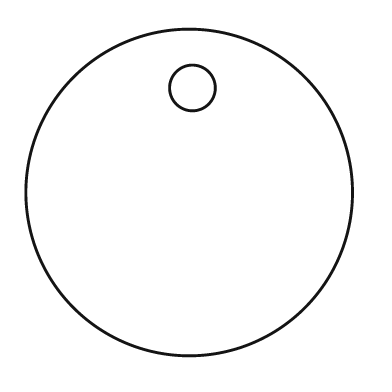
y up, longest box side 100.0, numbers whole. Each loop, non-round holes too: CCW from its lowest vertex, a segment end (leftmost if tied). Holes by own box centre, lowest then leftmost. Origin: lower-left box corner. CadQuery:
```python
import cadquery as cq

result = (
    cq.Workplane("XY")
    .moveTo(50.0, 50.0)
    .circle(50.0)
    .moveTo(51.0, 82.0)
    .circle(7.0)
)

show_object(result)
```